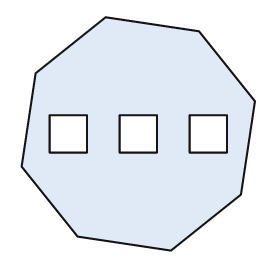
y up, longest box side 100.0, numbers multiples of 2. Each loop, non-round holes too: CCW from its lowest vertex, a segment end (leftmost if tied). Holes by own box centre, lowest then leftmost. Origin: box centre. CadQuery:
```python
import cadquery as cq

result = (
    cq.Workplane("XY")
    .moveTo(14.0, -50.0)
    .lineTo(44.0, -26.0)
    .lineTo(50.0, 14.0)
    .lineTo(26.0, 44.0)
    .lineTo(-14.0, 50.0)
    .lineTo(-44.0, 26.0)
    .lineTo(-50.0, -14.0)
    .lineTo(-26.0, -44.0)
    .close()
    .moveTo(-38.0, -8.0)
    .lineTo(-22.0, -8.0)
    .lineTo(-22.0, 8.0)
    .lineTo(-38.0, 8.0)
    .close()
    .moveTo(-8.0, -8.0)
    .lineTo(8.0, -8.0)
    .lineTo(8.0, 8.0)
    .lineTo(-8.0, 8.0)
    .close()
    .moveTo(22.0, -8.0)
    .lineTo(38.0, -8.0)
    .lineTo(38.0, 8.0)
    .lineTo(22.0, 8.0)
    .close()
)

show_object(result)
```